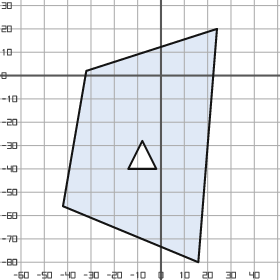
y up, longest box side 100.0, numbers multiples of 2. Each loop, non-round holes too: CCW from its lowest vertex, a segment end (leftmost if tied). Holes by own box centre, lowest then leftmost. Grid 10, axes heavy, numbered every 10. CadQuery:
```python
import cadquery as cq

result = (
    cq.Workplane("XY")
    .moveTo(16.0, -80.0)
    .lineTo(24.0, 20.0)
    .lineTo(-32.0, 2.0)
    .lineTo(-42.0, -56.0)
    .close()
    .moveTo(-14.0, -40.0)
    .lineTo(-2.0, -40.0)
    .lineTo(-8.0, -28.0)
    .close()
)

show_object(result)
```